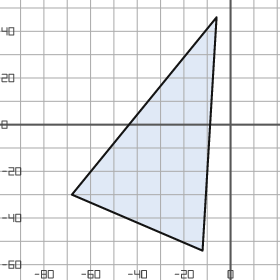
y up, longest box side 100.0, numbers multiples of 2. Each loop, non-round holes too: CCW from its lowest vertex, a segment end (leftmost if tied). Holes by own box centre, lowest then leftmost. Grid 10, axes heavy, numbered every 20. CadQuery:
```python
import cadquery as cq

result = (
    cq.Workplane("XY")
    .moveTo(-12.0, -54.0)
    .lineTo(-6.0, 46.0)
    .lineTo(-68.0, -30.0)
    .close()
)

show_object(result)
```